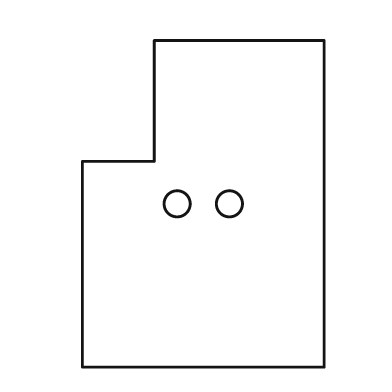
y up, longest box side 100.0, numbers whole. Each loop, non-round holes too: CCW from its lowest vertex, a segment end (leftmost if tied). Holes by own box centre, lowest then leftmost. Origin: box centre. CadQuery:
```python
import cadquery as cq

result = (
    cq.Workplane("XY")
    .moveTo(-37.0, -50.0)
    .lineTo(37.0, -50.0)
    .lineTo(37.0, 50.0)
    .lineTo(-15.0, 50.0)
    .lineTo(-15.0, 13.0)
    .lineTo(-37.0, 13.0)
    .close()
    .moveTo(-8.0, 0.0)
    .circle(4.0)
    .moveTo(8.0, 0.0)
    .circle(4.0)
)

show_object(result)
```